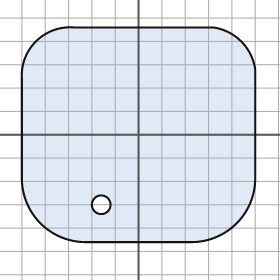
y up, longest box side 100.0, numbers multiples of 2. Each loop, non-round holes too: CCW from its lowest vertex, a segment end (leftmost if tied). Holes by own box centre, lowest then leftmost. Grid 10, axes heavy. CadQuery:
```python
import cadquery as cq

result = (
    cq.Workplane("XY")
    .moveTo(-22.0, -46.0)
    .lineTo(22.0, -46.0)
    .threePointArc((42.0, -38.0), (50.0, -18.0))
    .lineTo(50.0, 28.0)
    .threePointArc((44.0, 40.0), (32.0, 46.0))
    .lineTo(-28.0, 46.0)
    .threePointArc((-44.0, 40.0), (-50.0, 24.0))
    .lineTo(-50.0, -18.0)
    .threePointArc((-42.0, -38.0), (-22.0, -46.0))
    .close()
    .moveTo(-16.0, -30.0)
    .circle(4.0)
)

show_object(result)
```